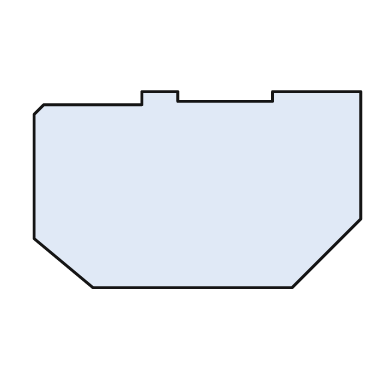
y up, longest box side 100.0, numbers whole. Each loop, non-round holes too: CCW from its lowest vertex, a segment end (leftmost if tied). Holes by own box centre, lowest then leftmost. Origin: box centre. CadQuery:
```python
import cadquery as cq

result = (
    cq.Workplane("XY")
    .moveTo(-32.0, -30.0)
    .lineTo(29.0, -30.0)
    .lineTo(50.0, -9.0)
    .lineTo(50.0, 30.0)
    .lineTo(23.0, 30.0)
    .lineTo(23.0, 27.0)
    .lineTo(-6.0, 27.0)
    .lineTo(-6.0, 30.0)
    .lineTo(-17.0, 30.0)
    .lineTo(-17.0, 26.0)
    .lineTo(-47.0, 26.0)
    .lineTo(-50.0, 23.0)
    .lineTo(-50.0, -15.0)
    .close()
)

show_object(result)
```